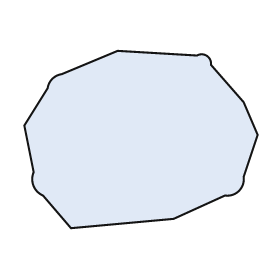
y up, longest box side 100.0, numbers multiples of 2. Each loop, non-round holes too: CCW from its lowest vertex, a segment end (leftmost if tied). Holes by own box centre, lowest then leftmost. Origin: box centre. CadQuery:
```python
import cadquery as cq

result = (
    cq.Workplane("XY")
    .moveTo(-30.0, -38.0)
    .lineTo(14.0, -34.0)
    .lineTo(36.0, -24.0)
    .threePointArc((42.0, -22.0), (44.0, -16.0))
    .lineTo(50.0, 2.0)
    .lineTo(44.0, 16.0)
    .lineTo(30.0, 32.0)
    .threePointArc((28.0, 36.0), (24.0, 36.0))
    .lineTo(-10.0, 38.0)
    .lineTo(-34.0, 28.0)
    .threePointArc((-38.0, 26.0), (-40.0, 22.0))
    .lineTo(-50.0, 6.0)
    .lineTo(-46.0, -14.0)
    .threePointArc((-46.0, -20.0), (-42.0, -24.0))
    .close()
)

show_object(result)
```